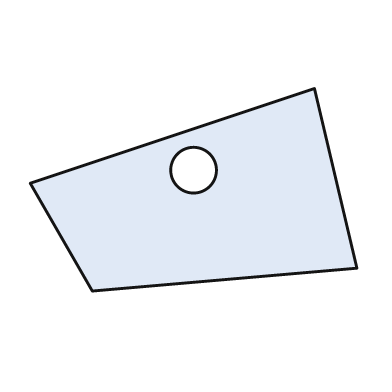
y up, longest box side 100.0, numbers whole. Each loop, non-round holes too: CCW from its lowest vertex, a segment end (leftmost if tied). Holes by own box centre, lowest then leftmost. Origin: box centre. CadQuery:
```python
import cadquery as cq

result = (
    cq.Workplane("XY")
    .moveTo(-31.0, -31.0)
    .lineTo(50.0, -24.0)
    .lineTo(37.0, 31.0)
    .lineTo(-50.0, 2.0)
    .close()
    .moveTo(0.0, 6.0)
    .circle(7.0)
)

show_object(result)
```